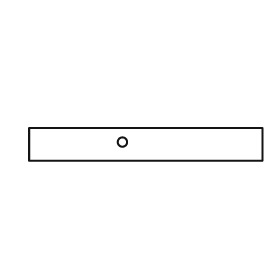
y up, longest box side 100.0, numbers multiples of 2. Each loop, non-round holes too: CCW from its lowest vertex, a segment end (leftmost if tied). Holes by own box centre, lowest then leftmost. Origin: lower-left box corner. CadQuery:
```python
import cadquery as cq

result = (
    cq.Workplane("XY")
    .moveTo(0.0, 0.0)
    .lineTo(100.0, 0.0)
    .lineTo(100.0, 14.0)
    .lineTo(0.0, 14.0)
    .close()
    .moveTo(40.0, 8.0)
    .circle(2.0)
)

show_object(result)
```